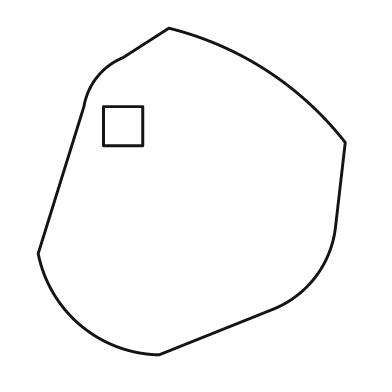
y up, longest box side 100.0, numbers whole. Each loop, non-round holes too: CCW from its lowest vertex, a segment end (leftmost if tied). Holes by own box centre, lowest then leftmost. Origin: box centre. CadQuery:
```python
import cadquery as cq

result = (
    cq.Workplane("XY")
    .moveTo(-10.0, -50.0)
    .lineTo(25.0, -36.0)
    .threePointArc((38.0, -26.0), (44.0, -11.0))
    .lineTo(47.0, 15.0)
    .threePointArc((23.0, 37.0), (-7.0, 50.0))
    .lineTo(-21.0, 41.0)
    .threePointArc((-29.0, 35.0), (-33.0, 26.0))
    .lineTo(-47.0, -19.0)
    .threePointArc((-34.0, -41.0), (-10.0, -50.0))
    .close()
    .moveTo(-27.0, 14.0)
    .lineTo(-15.0, 14.0)
    .lineTo(-15.0, 26.0)
    .lineTo(-27.0, 26.0)
    .close()
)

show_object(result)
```